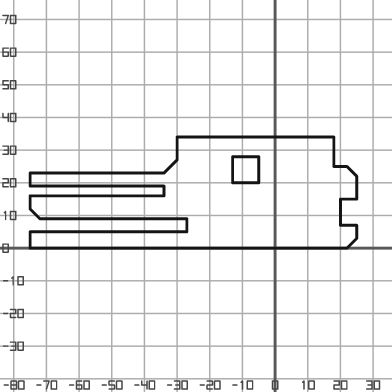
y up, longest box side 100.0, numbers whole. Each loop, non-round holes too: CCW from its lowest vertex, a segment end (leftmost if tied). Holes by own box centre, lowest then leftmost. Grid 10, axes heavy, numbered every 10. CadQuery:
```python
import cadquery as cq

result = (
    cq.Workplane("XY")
    .moveTo(-75.0, 0.0)
    .lineTo(22.0, 0.0)
    .lineTo(25.0, 3.0)
    .lineTo(25.0, 7.0)
    .lineTo(20.0, 7.0)
    .lineTo(20.0, 15.0)
    .lineTo(25.0, 15.0)
    .lineTo(25.0, 22.0)
    .lineTo(22.0, 25.0)
    .lineTo(18.0, 25.0)
    .lineTo(18.0, 34.0)
    .lineTo(-30.0, 34.0)
    .lineTo(-30.0, 27.0)
    .lineTo(-34.0, 23.0)
    .lineTo(-75.0, 23.0)
    .lineTo(-75.0, 19.0)
    .lineTo(-34.0, 19.0)
    .lineTo(-34.0, 16.0)
    .lineTo(-75.0, 16.0)
    .lineTo(-75.0, 12.0)
    .lineTo(-72.0, 9.0)
    .lineTo(-27.0, 9.0)
    .lineTo(-27.0, 5.0)
    .lineTo(-75.0, 5.0)
    .close()
    .moveTo(-13.0, 20.0)
    .lineTo(-5.0, 20.0)
    .lineTo(-5.0, 28.0)
    .lineTo(-13.0, 28.0)
    .close()
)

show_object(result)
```